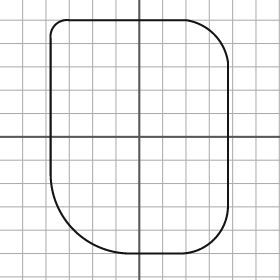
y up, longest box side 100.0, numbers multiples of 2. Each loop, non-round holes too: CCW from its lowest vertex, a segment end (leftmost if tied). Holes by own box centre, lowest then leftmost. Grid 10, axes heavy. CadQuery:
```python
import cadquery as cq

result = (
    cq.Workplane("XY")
    .moveTo(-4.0, -50.0)
    .lineTo(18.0, -50.0)
    .threePointArc((32.0, -44.0), (38.0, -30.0))
    .lineTo(38.0, 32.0)
    .threePointArc((32.0, 44.0), (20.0, 50.0))
    .lineTo(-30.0, 50.0)
    .threePointArc((-36.0, 48.0), (-38.0, 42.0))
    .lineTo(-38.0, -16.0)
    .threePointArc((-28.0, -40.0), (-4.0, -50.0))
    .close()
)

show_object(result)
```